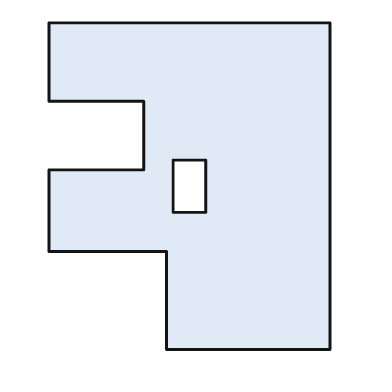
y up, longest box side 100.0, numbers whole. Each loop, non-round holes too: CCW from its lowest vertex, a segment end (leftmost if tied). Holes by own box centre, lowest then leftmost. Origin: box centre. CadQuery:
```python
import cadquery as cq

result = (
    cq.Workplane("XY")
    .moveTo(-7.0, -50.0)
    .lineTo(43.0, -50.0)
    .lineTo(43.0, 50.0)
    .lineTo(-43.0, 50.0)
    .lineTo(-43.0, 26.0)
    .lineTo(-14.0, 26.0)
    .lineTo(-14.0, 5.0)
    .lineTo(-43.0, 5.0)
    .lineTo(-43.0, -20.0)
    .lineTo(-7.0, -20.0)
    .close()
    .moveTo(-5.0, -8.0)
    .lineTo(5.0, -8.0)
    .lineTo(5.0, 8.0)
    .lineTo(-5.0, 8.0)
    .close()
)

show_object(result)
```